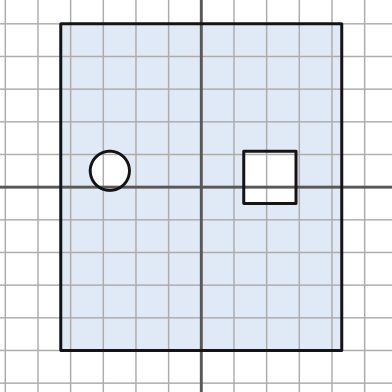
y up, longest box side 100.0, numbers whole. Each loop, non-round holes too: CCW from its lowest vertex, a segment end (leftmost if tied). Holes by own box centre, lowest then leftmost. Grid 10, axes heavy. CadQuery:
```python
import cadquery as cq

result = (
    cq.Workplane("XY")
    .moveTo(-43.0, -50.0)
    .lineTo(43.0, -50.0)
    .lineTo(43.0, 50.0)
    .lineTo(-43.0, 50.0)
    .close()
    .moveTo(13.0, -5.0)
    .lineTo(29.0, -5.0)
    .lineTo(29.0, 11.0)
    .lineTo(13.0, 11.0)
    .close()
    .moveTo(-28.0, 5.0)
    .circle(6.0)
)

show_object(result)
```